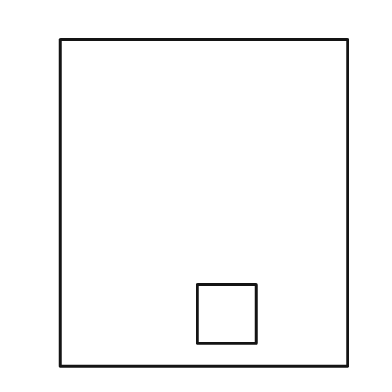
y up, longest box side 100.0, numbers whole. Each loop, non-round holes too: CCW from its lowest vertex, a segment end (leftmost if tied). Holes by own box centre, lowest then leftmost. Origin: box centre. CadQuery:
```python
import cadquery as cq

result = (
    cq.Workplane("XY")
    .moveTo(-44.0, -50.0)
    .lineTo(44.0, -50.0)
    .lineTo(44.0, 50.0)
    .lineTo(-44.0, 50.0)
    .close()
    .moveTo(-2.0, -43.0)
    .lineTo(16.0, -43.0)
    .lineTo(16.0, -25.0)
    .lineTo(-2.0, -25.0)
    .close()
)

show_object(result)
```